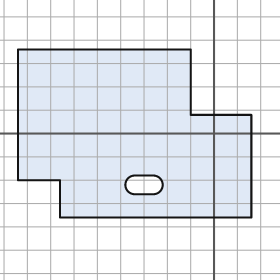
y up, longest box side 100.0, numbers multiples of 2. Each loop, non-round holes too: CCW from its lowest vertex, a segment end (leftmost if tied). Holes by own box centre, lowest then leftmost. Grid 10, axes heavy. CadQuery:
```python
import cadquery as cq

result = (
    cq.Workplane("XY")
    .moveTo(-66.0, -36.0)
    .lineTo(16.0, -36.0)
    .lineTo(16.0, 8.0)
    .lineTo(-10.0, 8.0)
    .lineTo(-10.0, 36.0)
    .lineTo(-84.0, 36.0)
    .lineTo(-84.0, -20.0)
    .lineTo(-66.0, -20.0)
    .close()
    .moveTo(-34.0, -26.0)
    .lineTo(-26.0, -26.0)
    .threePointArc((-22.0, -22.0), (-26.0, -18.0))
    .lineTo(-34.0, -18.0)
    .threePointArc((-38.0, -22.0), (-34.0, -26.0))
    .close()
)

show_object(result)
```